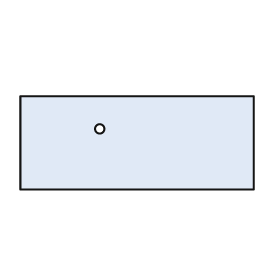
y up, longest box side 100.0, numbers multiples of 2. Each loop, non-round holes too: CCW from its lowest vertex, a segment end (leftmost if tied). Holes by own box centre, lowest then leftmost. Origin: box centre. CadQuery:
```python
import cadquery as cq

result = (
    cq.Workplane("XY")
    .moveTo(-50.0, -20.0)
    .lineTo(50.0, -20.0)
    .lineTo(50.0, 20.0)
    .lineTo(-50.0, 20.0)
    .close()
    .moveTo(-16.0, 6.0)
    .circle(2.0)
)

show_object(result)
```